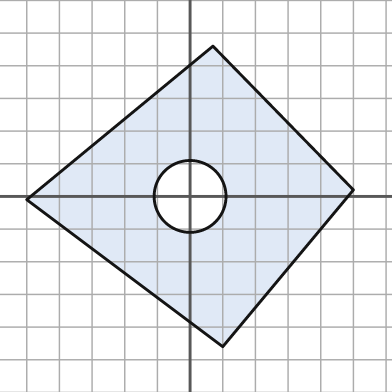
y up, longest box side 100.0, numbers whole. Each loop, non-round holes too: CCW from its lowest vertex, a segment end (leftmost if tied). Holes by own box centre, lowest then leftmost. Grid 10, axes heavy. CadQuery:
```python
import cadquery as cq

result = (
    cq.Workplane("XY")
    .moveTo(10.0, -46.0)
    .lineTo(50.0, 2.0)
    .lineTo(7.0, 46.0)
    .lineTo(-50.0, -1.0)
    .close()
    .moveTo(0.0, 0.0)
    .circle(11.0)
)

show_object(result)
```